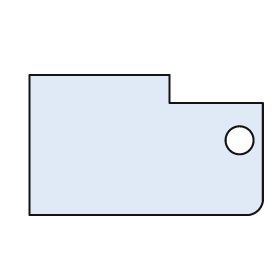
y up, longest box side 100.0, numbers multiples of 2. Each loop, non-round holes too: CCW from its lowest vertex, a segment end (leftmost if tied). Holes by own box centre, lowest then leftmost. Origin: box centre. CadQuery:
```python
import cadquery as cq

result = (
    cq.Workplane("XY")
    .moveTo(-50.0, -30.0)
    .lineTo(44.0, -30.0)
    .threePointArc((48.0, -28.0), (50.0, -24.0))
    .lineTo(50.0, 18.0)
    .lineTo(10.0, 18.0)
    .lineTo(10.0, 30.0)
    .lineTo(-50.0, 30.0)
    .close()
    .moveTo(40.0, 2.0)
    .circle(6.0)
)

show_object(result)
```